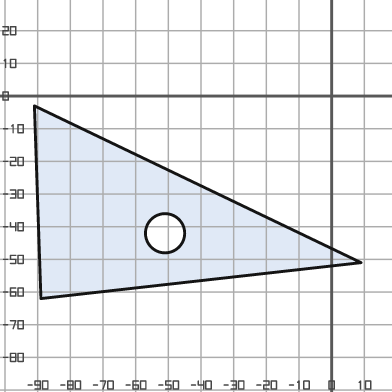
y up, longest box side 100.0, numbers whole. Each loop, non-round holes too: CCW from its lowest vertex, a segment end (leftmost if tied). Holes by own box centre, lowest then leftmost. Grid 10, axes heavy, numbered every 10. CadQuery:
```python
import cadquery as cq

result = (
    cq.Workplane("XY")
    .moveTo(-89.0, -62.0)
    .lineTo(9.0, -51.0)
    .lineTo(-91.0, -3.0)
    .close()
    .moveTo(-51.0, -42.0)
    .circle(6.0)
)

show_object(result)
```